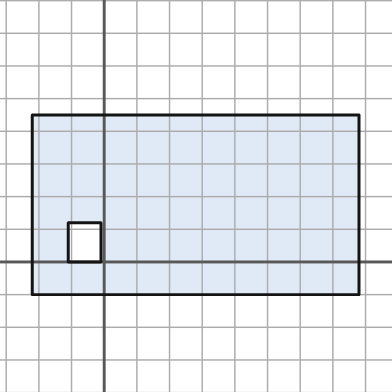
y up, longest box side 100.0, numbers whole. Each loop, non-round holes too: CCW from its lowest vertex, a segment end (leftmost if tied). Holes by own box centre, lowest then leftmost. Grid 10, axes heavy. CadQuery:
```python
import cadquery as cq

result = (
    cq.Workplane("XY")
    .moveTo(-22.0, -10.0)
    .lineTo(78.0, -10.0)
    .lineTo(78.0, 45.0)
    .lineTo(-22.0, 45.0)
    .close()
    .moveTo(-11.0, 0.0)
    .lineTo(-1.0, 0.0)
    .lineTo(-1.0, 12.0)
    .lineTo(-11.0, 12.0)
    .close()
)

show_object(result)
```